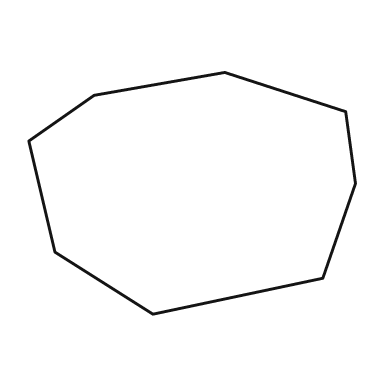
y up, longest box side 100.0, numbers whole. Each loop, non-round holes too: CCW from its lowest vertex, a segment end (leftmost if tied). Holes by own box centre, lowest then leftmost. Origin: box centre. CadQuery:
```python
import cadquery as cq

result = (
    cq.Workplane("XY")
    .moveTo(-12.0, -37.0)
    .lineTo(40.0, -26.0)
    .lineTo(50.0, 3.0)
    .lineTo(47.0, 25.0)
    .lineTo(10.0, 37.0)
    .lineTo(-30.0, 30.0)
    .lineTo(-50.0, 16.0)
    .lineTo(-42.0, -18.0)
    .close()
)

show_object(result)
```